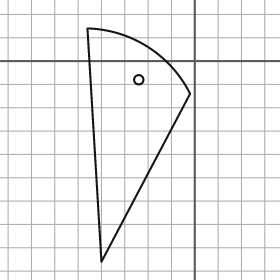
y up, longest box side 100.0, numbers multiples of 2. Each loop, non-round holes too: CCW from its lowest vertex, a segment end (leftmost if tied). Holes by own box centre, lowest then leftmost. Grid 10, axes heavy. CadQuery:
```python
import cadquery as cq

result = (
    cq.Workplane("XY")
    .moveTo(-40.0, -86.0)
    .lineTo(-2.0, -14.0)
    .threePointArc((-20.0, 6.0), (-46.0, 14.0))
    .close()
    .moveTo(-24.0, -8.0)
    .circle(2.0)
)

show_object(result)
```